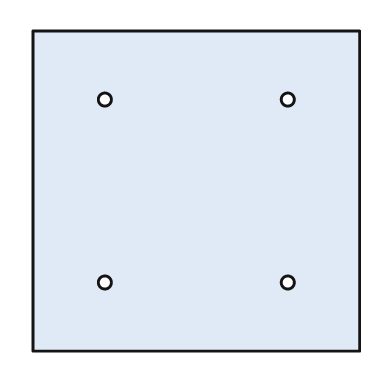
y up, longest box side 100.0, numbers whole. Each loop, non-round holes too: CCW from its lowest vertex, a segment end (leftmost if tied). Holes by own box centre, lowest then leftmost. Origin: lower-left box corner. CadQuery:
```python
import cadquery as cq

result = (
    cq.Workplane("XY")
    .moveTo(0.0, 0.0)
    .lineTo(100.0, 0.0)
    .lineTo(100.0, 98.0)
    .lineTo(0.0, 98.0)
    .close()
    .moveTo(22.0, 21.0)
    .circle(2.0)
    .moveTo(78.0, 21.0)
    .circle(2.0)
    .moveTo(22.0, 77.0)
    .circle(2.0)
    .moveTo(78.0, 77.0)
    .circle(2.0)
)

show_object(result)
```